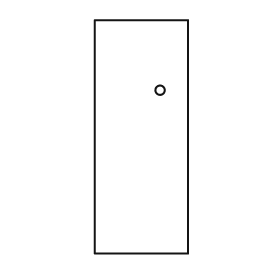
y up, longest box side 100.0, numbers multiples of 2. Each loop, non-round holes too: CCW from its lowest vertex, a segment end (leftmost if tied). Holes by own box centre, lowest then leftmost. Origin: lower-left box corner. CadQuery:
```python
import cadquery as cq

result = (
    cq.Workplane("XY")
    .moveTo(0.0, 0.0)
    .lineTo(40.0, 0.0)
    .lineTo(40.0, 100.0)
    .lineTo(0.0, 100.0)
    .close()
    .moveTo(28.0, 70.0)
    .circle(2.0)
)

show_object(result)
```